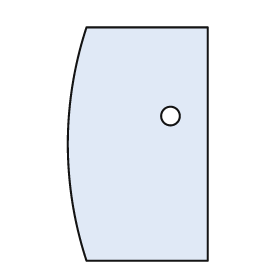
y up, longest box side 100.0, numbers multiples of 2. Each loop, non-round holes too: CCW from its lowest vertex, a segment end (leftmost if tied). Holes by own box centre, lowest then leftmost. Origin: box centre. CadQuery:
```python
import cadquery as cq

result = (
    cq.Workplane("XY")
    .moveTo(-22.0, -50.0)
    .lineTo(30.0, -50.0)
    .lineTo(30.0, 50.0)
    .lineTo(-22.0, 50.0)
    .threePointArc((-30.0, 0.0), (-22.0, -50.0))
    .close()
    .moveTo(14.0, 12.0)
    .circle(4.0)
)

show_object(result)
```